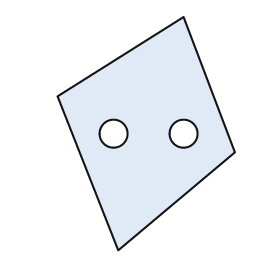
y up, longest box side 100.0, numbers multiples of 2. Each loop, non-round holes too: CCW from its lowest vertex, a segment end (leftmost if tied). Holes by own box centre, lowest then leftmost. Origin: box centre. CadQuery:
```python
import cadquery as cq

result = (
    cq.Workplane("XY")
    .moveTo(-12.0, -50.0)
    .lineTo(38.0, -8.0)
    .lineTo(16.0, 50.0)
    .lineTo(-38.0, 16.0)
    .close()
    .moveTo(-14.0, 0.0)
    .circle(6.0)
    .moveTo(16.0, 0.0)
    .circle(6.0)
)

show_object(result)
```